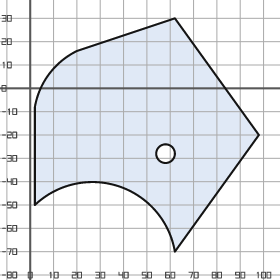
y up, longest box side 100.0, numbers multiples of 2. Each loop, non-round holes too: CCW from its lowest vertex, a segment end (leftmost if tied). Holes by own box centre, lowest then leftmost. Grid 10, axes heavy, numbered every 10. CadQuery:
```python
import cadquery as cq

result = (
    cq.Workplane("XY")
    .moveTo(62.0, -70.0)
    .lineTo(98.0, -20.0)
    .lineTo(62.0, 30.0)
    .lineTo(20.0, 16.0)
    .threePointArc((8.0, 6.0), (2.0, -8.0))
    .lineTo(2.0, -50.0)
    .threePointArc((38.0, -42.0), (62.0, -70.0))
    .close()
    .moveTo(58.0, -28.0)
    .circle(4.0)
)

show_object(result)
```